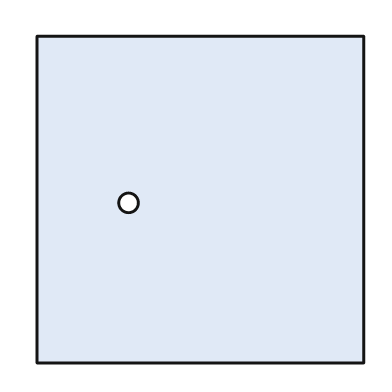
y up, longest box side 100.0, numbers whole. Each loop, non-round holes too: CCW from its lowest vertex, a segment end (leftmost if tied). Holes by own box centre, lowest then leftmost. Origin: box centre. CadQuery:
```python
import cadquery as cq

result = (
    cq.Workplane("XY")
    .moveTo(-50.0, -50.0)
    .lineTo(50.0, -50.0)
    .lineTo(50.0, 50.0)
    .lineTo(-50.0, 50.0)
    .close()
    .moveTo(-22.0, -1.0)
    .circle(3.0)
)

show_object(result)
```